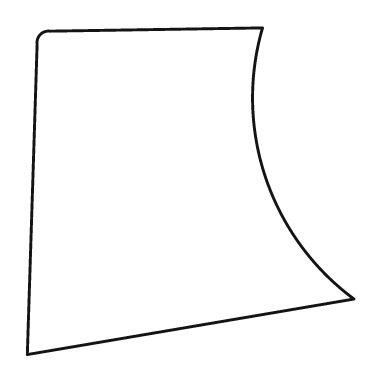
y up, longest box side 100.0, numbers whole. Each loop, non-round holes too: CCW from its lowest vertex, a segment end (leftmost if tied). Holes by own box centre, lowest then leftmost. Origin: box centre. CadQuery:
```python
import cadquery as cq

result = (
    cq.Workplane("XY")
    .moveTo(-50.0, -50.0)
    .lineTo(50.0, -33.0)
    .threePointArc((23.0, 4.0), (22.0, 50.0))
    .lineTo(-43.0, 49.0)
    .threePointArc((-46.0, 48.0), (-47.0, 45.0))
    .close()
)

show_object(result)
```